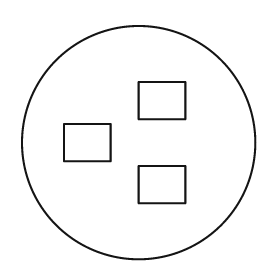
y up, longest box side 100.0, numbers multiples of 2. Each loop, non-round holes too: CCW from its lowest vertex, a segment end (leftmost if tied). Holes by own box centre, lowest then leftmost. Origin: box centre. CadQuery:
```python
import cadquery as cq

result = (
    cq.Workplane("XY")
    .moveTo(0.0, 0.0)
    .circle(50.0)
    .moveTo(0.0, -26.0)
    .lineTo(20.0, -26.0)
    .lineTo(20.0, -10.0)
    .lineTo(0.0, -10.0)
    .close()
    .moveTo(-32.0, -8.0)
    .lineTo(-12.0, -8.0)
    .lineTo(-12.0, 8.0)
    .lineTo(-32.0, 8.0)
    .close()
    .moveTo(0.0, 10.0)
    .lineTo(20.0, 10.0)
    .lineTo(20.0, 26.0)
    .lineTo(0.0, 26.0)
    .close()
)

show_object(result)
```